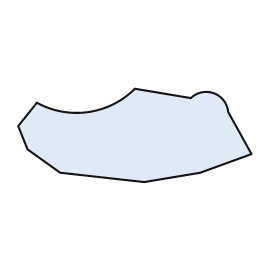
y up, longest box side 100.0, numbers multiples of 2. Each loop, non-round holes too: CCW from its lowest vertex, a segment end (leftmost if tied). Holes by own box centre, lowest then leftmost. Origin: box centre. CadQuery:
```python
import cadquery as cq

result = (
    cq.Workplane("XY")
    .moveTo(4.0, -20.0)
    .lineTo(28.0, -16.0)
    .lineTo(50.0, -8.0)
    .lineTo(40.0, 10.0)
    .threePointArc((34.0, 18.0), (24.0, 16.0))
    .lineTo(0.0, 20.0)
    .threePointArc((-20.0, 10.0), (-42.0, 14.0))
    .lineTo(-50.0, 4.0)
    .lineTo(-46.0, -6.0)
    .lineTo(-32.0, -16.0)
    .close()
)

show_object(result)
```